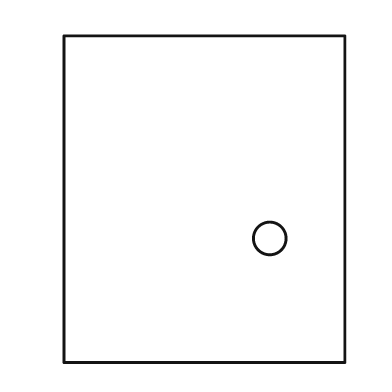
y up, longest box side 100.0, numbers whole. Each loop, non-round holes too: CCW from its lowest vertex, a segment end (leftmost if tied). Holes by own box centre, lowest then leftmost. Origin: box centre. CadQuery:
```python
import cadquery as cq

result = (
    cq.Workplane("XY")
    .moveTo(-43.0, -50.0)
    .lineTo(43.0, -50.0)
    .lineTo(43.0, 50.0)
    .lineTo(-43.0, 50.0)
    .close()
    .moveTo(20.0, -12.0)
    .circle(5.0)
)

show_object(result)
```